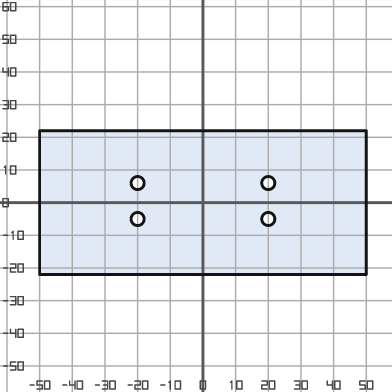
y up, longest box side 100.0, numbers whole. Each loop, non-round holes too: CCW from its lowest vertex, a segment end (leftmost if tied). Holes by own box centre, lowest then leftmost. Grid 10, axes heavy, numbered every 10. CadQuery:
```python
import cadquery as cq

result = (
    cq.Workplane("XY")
    .moveTo(-50.0, -22.0)
    .lineTo(50.0, -22.0)
    .lineTo(50.0, 22.0)
    .lineTo(-50.0, 22.0)
    .close()
    .moveTo(-20.0, -5.0)
    .circle(2.0)
    .moveTo(20.0, -5.0)
    .circle(2.0)
    .moveTo(-20.0, 6.0)
    .circle(2.0)
    .moveTo(20.0, 6.0)
    .circle(2.0)
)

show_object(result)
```